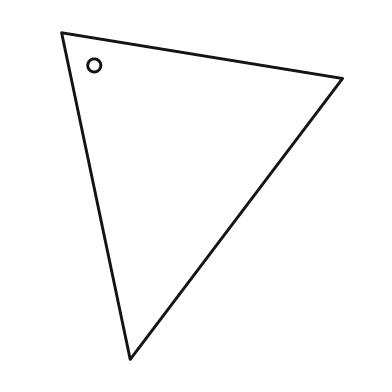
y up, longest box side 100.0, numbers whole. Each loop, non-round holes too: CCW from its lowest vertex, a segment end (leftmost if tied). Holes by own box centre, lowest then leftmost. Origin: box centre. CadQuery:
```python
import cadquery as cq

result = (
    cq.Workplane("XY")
    .moveTo(-22.0, -50.0)
    .lineTo(43.0, 36.0)
    .lineTo(-43.0, 50.0)
    .close()
    .moveTo(-33.0, 40.0)
    .circle(2.0)
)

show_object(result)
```